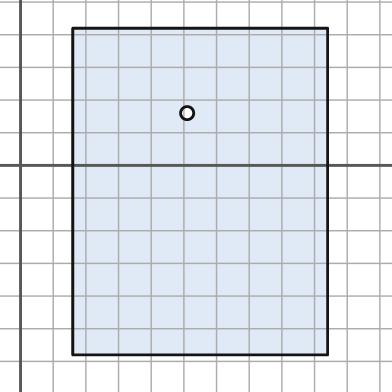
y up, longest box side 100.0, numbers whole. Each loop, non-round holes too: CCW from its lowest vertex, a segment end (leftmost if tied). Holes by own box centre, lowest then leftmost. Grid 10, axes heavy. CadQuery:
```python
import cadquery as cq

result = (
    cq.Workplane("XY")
    .moveTo(16.0, -58.0)
    .lineTo(94.0, -58.0)
    .lineTo(94.0, 42.0)
    .lineTo(16.0, 42.0)
    .close()
    .moveTo(51.0, 16.0)
    .circle(2.0)
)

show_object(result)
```